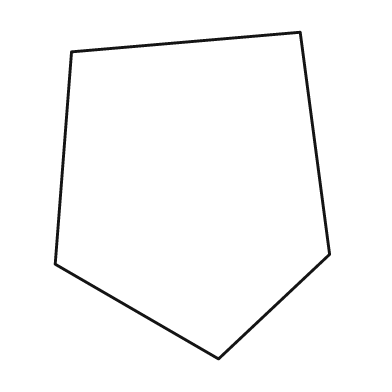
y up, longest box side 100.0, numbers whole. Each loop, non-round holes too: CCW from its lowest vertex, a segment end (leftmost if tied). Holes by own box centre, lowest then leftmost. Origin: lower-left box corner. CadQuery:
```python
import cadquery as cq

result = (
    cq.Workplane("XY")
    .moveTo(50.0, 0.0)
    .lineTo(84.0, 32.0)
    .lineTo(75.0, 100.0)
    .lineTo(5.0, 94.0)
    .lineTo(0.0, 29.0)
    .close()
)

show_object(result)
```